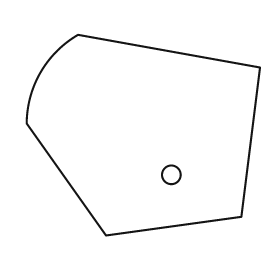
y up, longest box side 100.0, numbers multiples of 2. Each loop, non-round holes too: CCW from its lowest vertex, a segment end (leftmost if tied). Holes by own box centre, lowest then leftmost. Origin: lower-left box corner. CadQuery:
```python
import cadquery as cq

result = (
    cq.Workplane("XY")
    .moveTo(34.0, 0.0)
    .lineTo(92.0, 8.0)
    .lineTo(100.0, 72.0)
    .lineTo(22.0, 86.0)
    .threePointArc((6.0, 70.0), (0.0, 48.0))
    .close()
    .moveTo(62.0, 26.0)
    .circle(4.0)
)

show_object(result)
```